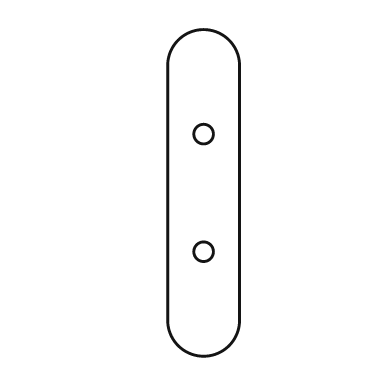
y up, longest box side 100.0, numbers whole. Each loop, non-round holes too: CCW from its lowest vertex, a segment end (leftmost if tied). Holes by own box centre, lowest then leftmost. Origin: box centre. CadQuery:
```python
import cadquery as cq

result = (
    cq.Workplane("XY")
    .moveTo(-11.0, -39.0)
    .threePointArc((0.0, -50.0), (11.0, -39.0))
    .lineTo(11.0, 39.0)
    .threePointArc((0.0, 50.0), (-11.0, 39.0))
    .close()
    .moveTo(0.0, -18.0)
    .circle(3.0)
    .moveTo(0.0, 18.0)
    .circle(3.0)
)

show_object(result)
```